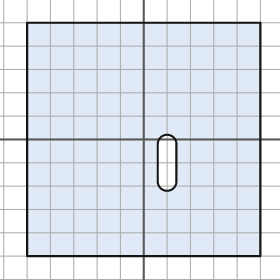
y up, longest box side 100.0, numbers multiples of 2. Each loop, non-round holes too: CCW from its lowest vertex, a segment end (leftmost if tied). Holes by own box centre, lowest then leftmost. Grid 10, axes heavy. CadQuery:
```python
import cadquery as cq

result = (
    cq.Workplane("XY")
    .moveTo(-50.0, -50.0)
    .lineTo(50.0, -50.0)
    .lineTo(50.0, 50.0)
    .lineTo(-50.0, 50.0)
    .close()
    .moveTo(6.0, -18.0)
    .threePointArc((10.0, -22.0), (14.0, -18.0))
    .lineTo(14.0, -2.0)
    .threePointArc((10.0, 2.0), (6.0, -2.0))
    .close()
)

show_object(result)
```